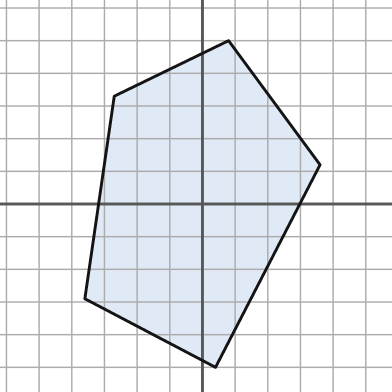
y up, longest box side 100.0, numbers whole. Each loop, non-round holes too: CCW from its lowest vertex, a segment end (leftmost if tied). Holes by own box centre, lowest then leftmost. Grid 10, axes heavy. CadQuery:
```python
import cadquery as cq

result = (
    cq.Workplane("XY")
    .moveTo(4.0, -50.0)
    .lineTo(36.0, 12.0)
    .lineTo(8.0, 50.0)
    .lineTo(-27.0, 33.0)
    .lineTo(-36.0, -29.0)
    .close()
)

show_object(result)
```